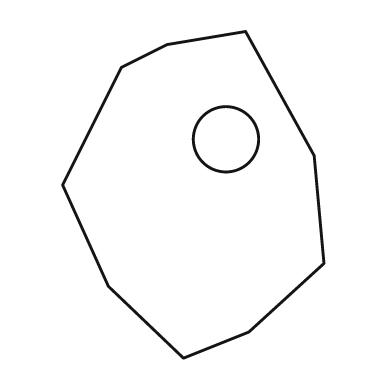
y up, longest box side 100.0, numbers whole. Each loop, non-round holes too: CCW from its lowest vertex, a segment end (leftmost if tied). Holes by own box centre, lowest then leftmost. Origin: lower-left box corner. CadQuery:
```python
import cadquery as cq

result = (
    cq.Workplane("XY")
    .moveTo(37.0, 0.0)
    .lineTo(57.0, 8.0)
    .lineTo(80.0, 29.0)
    .lineTo(77.0, 62.0)
    .lineTo(56.0, 100.0)
    .lineTo(32.0, 96.0)
    .lineTo(18.0, 89.0)
    .lineTo(0.0, 53.0)
    .lineTo(14.0, 22.0)
    .close()
    .moveTo(50.0, 67.0)
    .circle(10.0)
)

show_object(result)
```